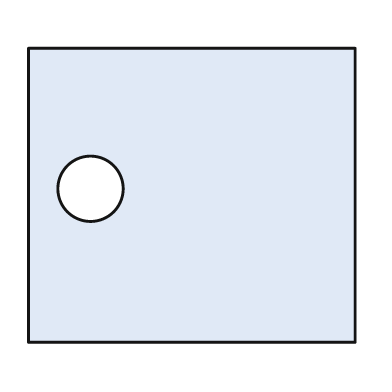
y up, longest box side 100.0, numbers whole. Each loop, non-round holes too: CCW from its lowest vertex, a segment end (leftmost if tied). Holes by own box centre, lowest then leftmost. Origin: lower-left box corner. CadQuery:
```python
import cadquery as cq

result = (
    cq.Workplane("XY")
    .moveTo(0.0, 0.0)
    .lineTo(100.0, 0.0)
    .lineTo(100.0, 90.0)
    .lineTo(0.0, 90.0)
    .close()
    .moveTo(19.0, 47.0)
    .circle(10.0)
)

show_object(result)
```